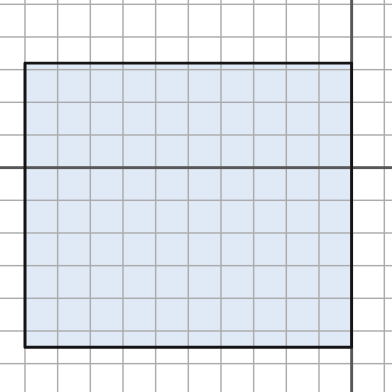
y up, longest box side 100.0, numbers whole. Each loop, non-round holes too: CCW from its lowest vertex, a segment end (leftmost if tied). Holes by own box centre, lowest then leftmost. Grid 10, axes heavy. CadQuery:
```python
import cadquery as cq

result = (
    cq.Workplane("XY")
    .moveTo(-100.0, -55.0)
    .lineTo(0.0, -55.0)
    .lineTo(0.0, 32.0)
    .lineTo(-100.0, 32.0)
    .close()
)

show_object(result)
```